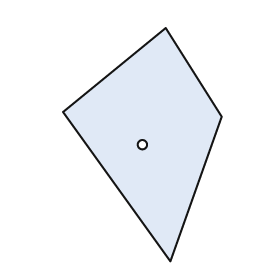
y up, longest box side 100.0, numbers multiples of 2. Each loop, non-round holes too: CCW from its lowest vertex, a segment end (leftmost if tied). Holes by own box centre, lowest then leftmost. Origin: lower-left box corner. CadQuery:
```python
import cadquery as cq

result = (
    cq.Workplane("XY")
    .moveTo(46.0, 0.0)
    .lineTo(68.0, 62.0)
    .lineTo(44.0, 100.0)
    .lineTo(0.0, 64.0)
    .close()
    .moveTo(34.0, 50.0)
    .circle(2.0)
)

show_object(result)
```